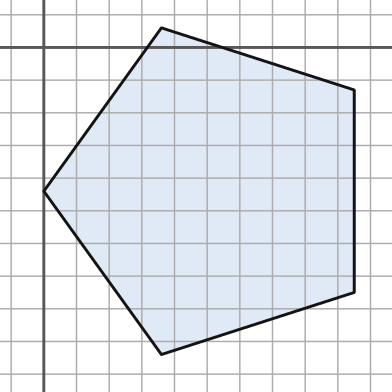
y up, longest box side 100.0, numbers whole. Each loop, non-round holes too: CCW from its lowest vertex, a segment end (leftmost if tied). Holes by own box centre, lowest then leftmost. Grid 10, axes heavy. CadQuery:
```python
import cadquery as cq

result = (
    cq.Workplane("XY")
    .moveTo(36.0, -94.0)
    .lineTo(95.0, -75.0)
    .lineTo(95.0, -13.0)
    .lineTo(36.0, 6.0)
    .lineTo(0.0, -44.0)
    .close()
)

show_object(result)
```